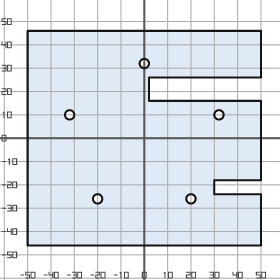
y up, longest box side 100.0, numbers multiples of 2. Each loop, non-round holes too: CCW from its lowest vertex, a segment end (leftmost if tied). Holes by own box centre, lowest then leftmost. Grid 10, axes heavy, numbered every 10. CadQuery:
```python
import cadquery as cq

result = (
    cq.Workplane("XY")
    .moveTo(-50.0, -46.0)
    .lineTo(50.0, -46.0)
    .lineTo(50.0, -24.0)
    .lineTo(30.0, -24.0)
    .lineTo(30.0, -18.0)
    .lineTo(50.0, -18.0)
    .lineTo(50.0, 16.0)
    .lineTo(2.0, 16.0)
    .lineTo(2.0, 26.0)
    .lineTo(50.0, 26.0)
    .lineTo(50.0, 46.0)
    .lineTo(-50.0, 46.0)
    .close()
    .moveTo(-20.0, -26.0)
    .circle(2.0)
    .moveTo(20.0, -26.0)
    .circle(2.0)
    .moveTo(-32.0, 10.0)
    .circle(2.0)
    .moveTo(32.0, 10.0)
    .circle(2.0)
    .moveTo(0.0, 32.0)
    .circle(2.0)
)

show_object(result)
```